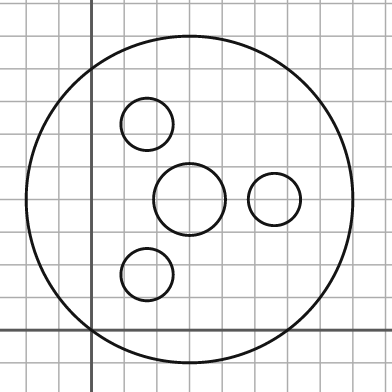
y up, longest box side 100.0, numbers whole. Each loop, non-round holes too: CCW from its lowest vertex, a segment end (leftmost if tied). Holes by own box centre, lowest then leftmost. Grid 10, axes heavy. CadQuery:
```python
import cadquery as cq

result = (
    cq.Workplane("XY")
    .moveTo(30.0, 40.0)
    .circle(50.0)
    .moveTo(17.0, 17.0)
    .circle(8.0)
    .moveTo(30.0, 40.0)
    .circle(11.0)
    .moveTo(56.0, 40.0)
    .circle(8.0)
    .moveTo(17.0, 63.0)
    .circle(8.0)
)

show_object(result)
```